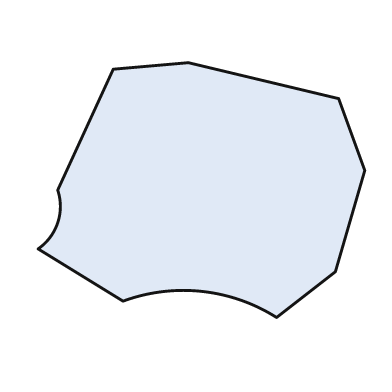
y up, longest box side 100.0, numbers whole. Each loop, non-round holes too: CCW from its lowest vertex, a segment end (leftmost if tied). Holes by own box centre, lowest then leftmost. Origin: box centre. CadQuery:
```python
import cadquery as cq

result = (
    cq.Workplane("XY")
    .moveTo(23.0, -39.0)
    .lineTo(41.0, -25.0)
    .lineTo(50.0, 6.0)
    .lineTo(42.0, 28.0)
    .lineTo(-4.0, 39.0)
    .lineTo(-27.0, 37.0)
    .lineTo(-44.0, 0.0)
    .threePointArc((-44.0, -10.0), (-50.0, -18.0))
    .lineTo(-24.0, -34.0)
    .threePointArc((0.0, -31.0), (23.0, -39.0))
    .close()
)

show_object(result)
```